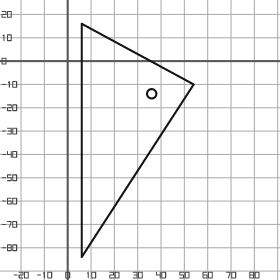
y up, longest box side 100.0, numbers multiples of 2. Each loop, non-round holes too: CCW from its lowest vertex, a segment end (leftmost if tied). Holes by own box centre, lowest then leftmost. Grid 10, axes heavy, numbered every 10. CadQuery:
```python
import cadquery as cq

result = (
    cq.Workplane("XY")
    .moveTo(6.0, -84.0)
    .lineTo(54.0, -10.0)
    .lineTo(6.0, 16.0)
    .close()
    .moveTo(36.0, -14.0)
    .circle(2.0)
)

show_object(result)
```